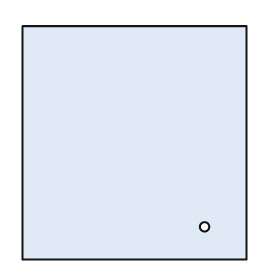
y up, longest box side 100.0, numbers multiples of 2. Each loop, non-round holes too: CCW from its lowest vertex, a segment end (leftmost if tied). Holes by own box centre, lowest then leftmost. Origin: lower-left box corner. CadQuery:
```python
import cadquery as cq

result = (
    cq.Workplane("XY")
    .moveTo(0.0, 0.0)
    .lineTo(96.0, 0.0)
    .lineTo(96.0, 100.0)
    .lineTo(0.0, 100.0)
    .close()
    .moveTo(78.0, 14.0)
    .circle(2.0)
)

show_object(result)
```